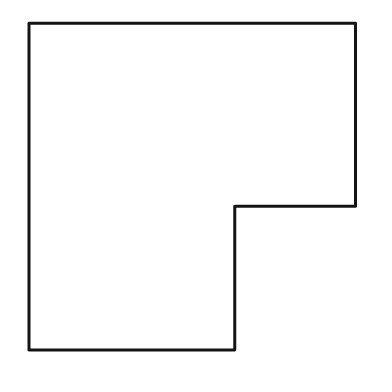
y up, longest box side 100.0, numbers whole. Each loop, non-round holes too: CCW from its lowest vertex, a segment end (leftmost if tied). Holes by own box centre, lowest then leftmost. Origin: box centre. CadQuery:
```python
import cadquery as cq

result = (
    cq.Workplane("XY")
    .moveTo(-50.0, -50.0)
    .lineTo(13.0, -50.0)
    .lineTo(13.0, -6.0)
    .lineTo(50.0, -6.0)
    .lineTo(50.0, 50.0)
    .lineTo(-50.0, 50.0)
    .close()
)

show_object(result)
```